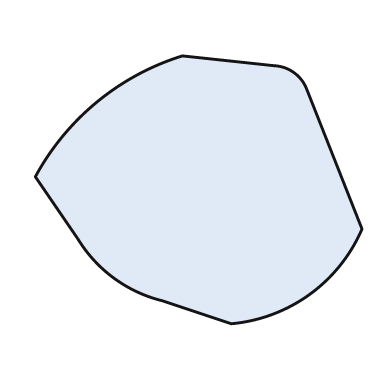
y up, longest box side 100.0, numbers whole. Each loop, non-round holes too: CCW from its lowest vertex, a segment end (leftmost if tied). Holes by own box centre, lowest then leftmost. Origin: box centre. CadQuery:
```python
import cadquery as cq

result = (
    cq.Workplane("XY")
    .moveTo(10.0, -41.0)
    .threePointArc((34.0, -32.0), (50.0, -12.0))
    .lineTo(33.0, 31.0)
    .threePointArc((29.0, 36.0), (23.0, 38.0))
    .lineTo(-5.0, 41.0)
    .threePointArc((-31.0, 27.0), (-50.0, 4.0))
    .lineTo(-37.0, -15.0)
    .threePointArc((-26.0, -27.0), (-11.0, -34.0))
    .close()
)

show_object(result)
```